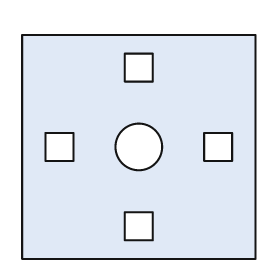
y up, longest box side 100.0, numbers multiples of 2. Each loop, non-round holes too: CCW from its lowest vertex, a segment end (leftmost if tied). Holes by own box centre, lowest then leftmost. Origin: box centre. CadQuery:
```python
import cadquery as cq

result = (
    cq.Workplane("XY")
    .moveTo(-50.0, -48.0)
    .lineTo(50.0, -48.0)
    .lineTo(50.0, 48.0)
    .lineTo(-50.0, 48.0)
    .close()
    .moveTo(-6.0, -40.0)
    .lineTo(6.0, -40.0)
    .lineTo(6.0, -28.0)
    .lineTo(-6.0, -28.0)
    .close()
    .moveTo(-40.0, -6.0)
    .lineTo(-28.0, -6.0)
    .lineTo(-28.0, 6.0)
    .lineTo(-40.0, 6.0)
    .close()
    .moveTo(0.0, 0.0)
    .circle(10.0)
    .moveTo(28.0, -6.0)
    .lineTo(40.0, -6.0)
    .lineTo(40.0, 6.0)
    .lineTo(28.0, 6.0)
    .close()
    .moveTo(-6.0, 28.0)
    .lineTo(6.0, 28.0)
    .lineTo(6.0, 40.0)
    .lineTo(-6.0, 40.0)
    .close()
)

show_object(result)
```